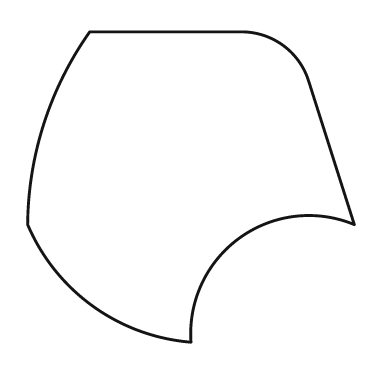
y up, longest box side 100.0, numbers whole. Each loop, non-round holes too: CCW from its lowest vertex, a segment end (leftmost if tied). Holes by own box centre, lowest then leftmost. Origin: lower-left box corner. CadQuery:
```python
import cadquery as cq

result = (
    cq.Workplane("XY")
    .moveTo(50.0, 0.0)
    .threePointArc((65.0, 32.0), (100.0, 36.0))
    .lineTo(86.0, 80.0)
    .threePointArc((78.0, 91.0), (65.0, 95.0))
    .lineTo(19.0, 95.0)
    .threePointArc((5.0, 67.0), (0.0, 36.0))
    .threePointArc((20.0, 11.0), (50.0, 0.0))
    .close()
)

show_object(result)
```